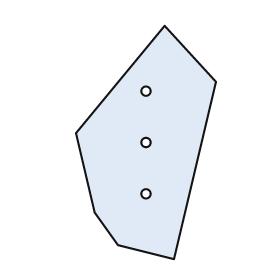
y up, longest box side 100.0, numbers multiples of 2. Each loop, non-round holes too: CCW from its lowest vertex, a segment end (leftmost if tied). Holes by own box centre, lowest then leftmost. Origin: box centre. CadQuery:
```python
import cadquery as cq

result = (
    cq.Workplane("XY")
    .moveTo(12.0, -50.0)
    .lineTo(30.0, 26.0)
    .lineTo(8.0, 50.0)
    .lineTo(-30.0, 4.0)
    .lineTo(-22.0, -30.0)
    .lineTo(-12.0, -44.0)
    .close()
    .moveTo(0.0, -22.0)
    .circle(2.0)
    .moveTo(0.0, 0.0)
    .circle(2.0)
    .moveTo(0.0, 22.0)
    .circle(2.0)
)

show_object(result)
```